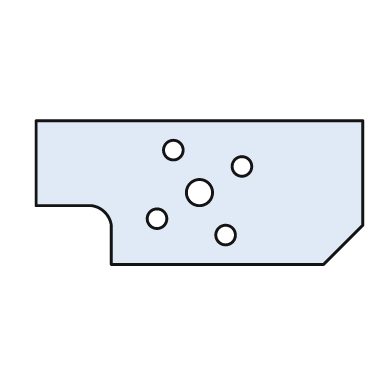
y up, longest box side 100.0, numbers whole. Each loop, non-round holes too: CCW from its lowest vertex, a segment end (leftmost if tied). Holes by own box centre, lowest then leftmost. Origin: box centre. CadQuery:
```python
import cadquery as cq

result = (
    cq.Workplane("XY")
    .moveTo(-27.0, -22.0)
    .lineTo(38.0, -22.0)
    .lineTo(50.0, -10.0)
    .lineTo(50.0, 22.0)
    .lineTo(-50.0, 22.0)
    .lineTo(-50.0, -4.0)
    .lineTo(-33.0, -4.0)
    .threePointArc((-29.0, -6.0), (-27.0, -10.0))
    .close()
    .moveTo(8.0, -13.0)
    .circle(3.0)
    .moveTo(-13.0, -8.0)
    .circle(3.0)
    .moveTo(0.0, 0.0)
    .circle(4.0)
    .moveTo(13.0, 8.0)
    .circle(3.0)
    .moveTo(-8.0, 13.0)
    .circle(3.0)
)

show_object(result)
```